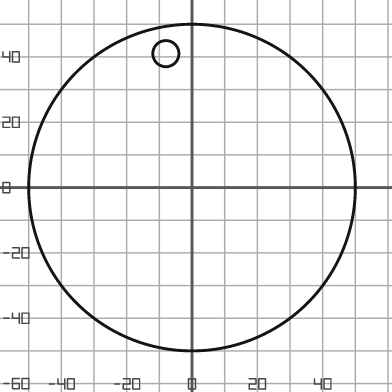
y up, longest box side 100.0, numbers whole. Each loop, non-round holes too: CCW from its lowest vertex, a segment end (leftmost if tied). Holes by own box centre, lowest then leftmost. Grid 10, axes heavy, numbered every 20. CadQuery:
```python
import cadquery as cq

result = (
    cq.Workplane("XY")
    .moveTo(0.0, 0.0)
    .circle(50.0)
    .moveTo(-8.0, 41.0)
    .circle(4.0)
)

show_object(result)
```